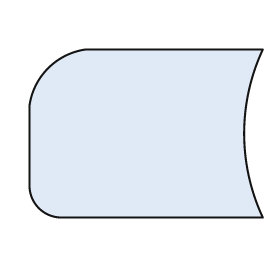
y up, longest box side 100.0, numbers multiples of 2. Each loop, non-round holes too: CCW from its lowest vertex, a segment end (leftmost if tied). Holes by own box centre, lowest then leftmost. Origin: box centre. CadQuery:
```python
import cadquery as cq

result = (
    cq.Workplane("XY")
    .moveTo(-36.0, -36.0)
    .lineTo(50.0, -36.0)
    .threePointArc((42.0, 0.0), (50.0, 36.0))
    .lineTo(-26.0, 36.0)
    .threePointArc((-42.0, 28.0), (-50.0, 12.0))
    .lineTo(-50.0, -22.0)
    .threePointArc((-46.0, -32.0), (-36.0, -36.0))
    .close()
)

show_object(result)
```